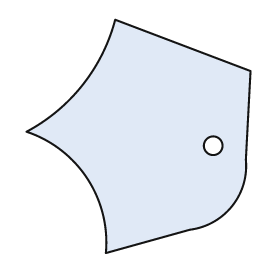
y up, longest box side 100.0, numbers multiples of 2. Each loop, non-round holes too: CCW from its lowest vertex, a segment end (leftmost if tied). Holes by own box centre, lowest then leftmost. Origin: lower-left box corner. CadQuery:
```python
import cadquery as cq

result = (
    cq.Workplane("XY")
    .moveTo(34.0, 0.0)
    .lineTo(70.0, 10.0)
    .threePointArc((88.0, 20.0), (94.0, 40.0))
    .lineTo(96.0, 78.0)
    .lineTo(38.0, 100.0)
    .threePointArc((24.0, 72.0), (0.0, 52.0))
    .threePointArc((26.0, 32.0), (34.0, 0.0))
    .close()
    .moveTo(80.0, 46.0)
    .circle(4.0)
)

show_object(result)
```